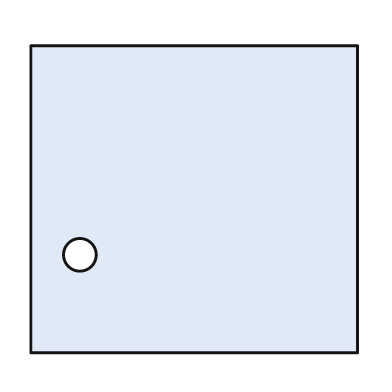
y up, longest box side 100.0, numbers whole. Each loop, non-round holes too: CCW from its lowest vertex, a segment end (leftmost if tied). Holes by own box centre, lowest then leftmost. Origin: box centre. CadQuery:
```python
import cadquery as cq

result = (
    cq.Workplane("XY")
    .moveTo(-50.0, -47.0)
    .lineTo(50.0, -47.0)
    .lineTo(50.0, 47.0)
    .lineTo(-50.0, 47.0)
    .close()
    .moveTo(-35.0, -17.0)
    .circle(5.0)
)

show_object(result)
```